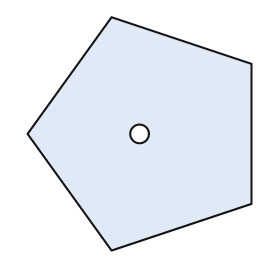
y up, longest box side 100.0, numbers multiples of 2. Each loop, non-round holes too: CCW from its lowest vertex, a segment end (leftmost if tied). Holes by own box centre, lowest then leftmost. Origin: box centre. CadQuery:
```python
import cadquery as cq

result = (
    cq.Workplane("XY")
    .moveTo(-12.0, -50.0)
    .lineTo(48.0, -30.0)
    .lineTo(48.0, 30.0)
    .lineTo(-12.0, 50.0)
    .lineTo(-48.0, 0.0)
    .close()
    .moveTo(0.0, 0.0)
    .circle(4.0)
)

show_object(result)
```